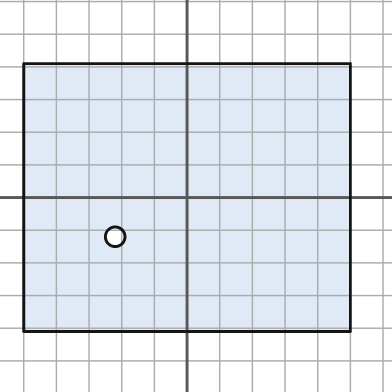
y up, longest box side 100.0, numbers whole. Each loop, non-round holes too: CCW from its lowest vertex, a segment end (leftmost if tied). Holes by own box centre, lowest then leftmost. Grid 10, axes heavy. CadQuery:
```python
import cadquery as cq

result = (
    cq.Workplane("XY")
    .moveTo(-50.0, -41.0)
    .lineTo(50.0, -41.0)
    .lineTo(50.0, 41.0)
    .lineTo(-50.0, 41.0)
    .close()
    .moveTo(-22.0, -12.0)
    .circle(3.0)
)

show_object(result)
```